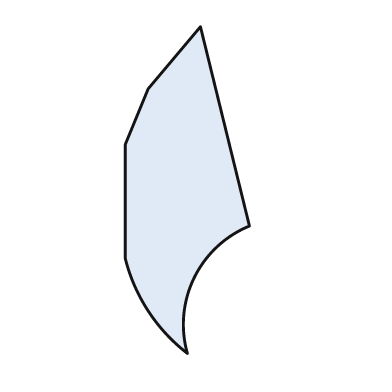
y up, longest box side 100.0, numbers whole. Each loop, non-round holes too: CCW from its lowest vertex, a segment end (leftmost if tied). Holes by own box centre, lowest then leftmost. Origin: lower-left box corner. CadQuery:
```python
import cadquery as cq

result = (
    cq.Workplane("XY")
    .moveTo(19.0, 0.0)
    .threePointArc((21.0, 23.0), (38.0, 39.0))
    .lineTo(23.0, 100.0)
    .lineTo(7.0, 81.0)
    .lineTo(0.0, 64.0)
    .lineTo(0.0, 29.0)
    .threePointArc((7.0, 13.0), (19.0, 0.0))
    .close()
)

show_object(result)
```